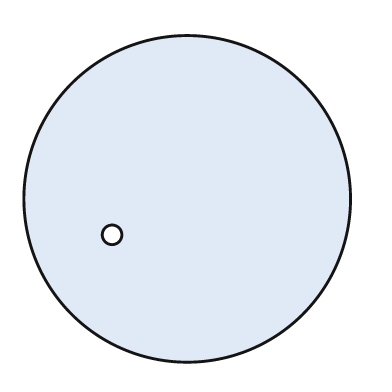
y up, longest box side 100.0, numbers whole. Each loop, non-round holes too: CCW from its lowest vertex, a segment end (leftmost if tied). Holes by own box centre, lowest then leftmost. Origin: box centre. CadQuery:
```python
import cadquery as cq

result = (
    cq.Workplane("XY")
    .moveTo(0.0, 0.0)
    .circle(50.0)
    .moveTo(-23.0, -11.0)
    .circle(3.0)
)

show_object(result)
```